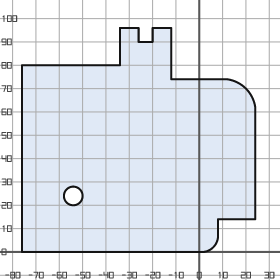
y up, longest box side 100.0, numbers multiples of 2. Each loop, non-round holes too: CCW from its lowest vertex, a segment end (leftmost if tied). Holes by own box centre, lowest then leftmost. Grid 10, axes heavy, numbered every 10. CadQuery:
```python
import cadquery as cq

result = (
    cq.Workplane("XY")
    .moveTo(-76.0, 0.0)
    .lineTo(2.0, 0.0)
    .threePointArc((6.0, 2.0), (8.0, 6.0))
    .lineTo(8.0, 14.0)
    .lineTo(24.0, 14.0)
    .lineTo(24.0, 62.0)
    .threePointArc((20.0, 70.0), (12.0, 74.0))
    .lineTo(-12.0, 74.0)
    .lineTo(-12.0, 96.0)
    .lineTo(-20.0, 96.0)
    .lineTo(-20.0, 90.0)
    .lineTo(-26.0, 90.0)
    .lineTo(-26.0, 96.0)
    .lineTo(-34.0, 96.0)
    .lineTo(-34.0, 80.0)
    .lineTo(-76.0, 80.0)
    .close()
    .moveTo(-54.0, 24.0)
    .circle(4.0)
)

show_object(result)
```